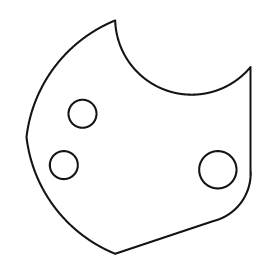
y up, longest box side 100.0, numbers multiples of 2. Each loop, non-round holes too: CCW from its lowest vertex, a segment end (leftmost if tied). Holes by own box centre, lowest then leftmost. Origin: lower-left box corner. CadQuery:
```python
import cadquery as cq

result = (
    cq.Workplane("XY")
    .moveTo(38.0, 0.0)
    .lineTo(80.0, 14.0)
    .threePointArc((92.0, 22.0), (96.0, 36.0))
    .lineTo(96.0, 80.0)
    .threePointArc((60.0, 70.0), (38.0, 100.0))
    .threePointArc((12.0, 80.0), (0.0, 50.0))
    .threePointArc((12.0, 20.0), (38.0, 0.0))
    .close()
    .moveTo(82.0, 36.0)
    .circle(8.0)
    .moveTo(16.0, 38.0)
    .circle(6.0)
    .moveTo(24.0, 60.0)
    .circle(6.0)
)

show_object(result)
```